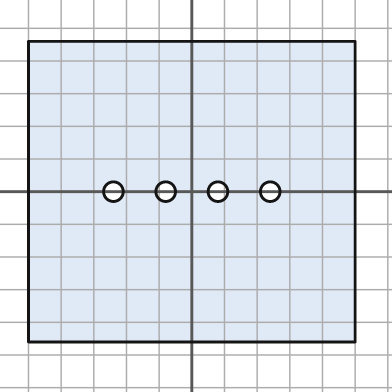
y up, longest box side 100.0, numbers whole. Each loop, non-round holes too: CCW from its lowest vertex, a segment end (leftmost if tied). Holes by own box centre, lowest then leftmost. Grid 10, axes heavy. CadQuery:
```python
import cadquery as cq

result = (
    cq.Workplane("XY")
    .moveTo(-50.0, -46.0)
    .lineTo(50.0, -46.0)
    .lineTo(50.0, 46.0)
    .lineTo(-50.0, 46.0)
    .close()
    .moveTo(-24.0, 0.0)
    .circle(3.0)
    .moveTo(-8.0, 0.0)
    .circle(3.0)
    .moveTo(8.0, 0.0)
    .circle(3.0)
    .moveTo(24.0, 0.0)
    .circle(3.0)
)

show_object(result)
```